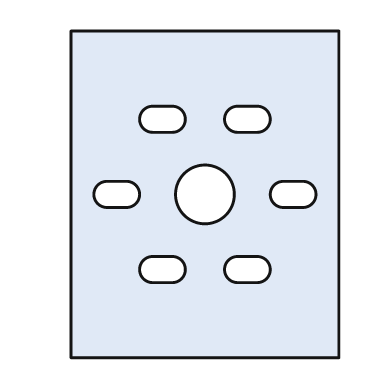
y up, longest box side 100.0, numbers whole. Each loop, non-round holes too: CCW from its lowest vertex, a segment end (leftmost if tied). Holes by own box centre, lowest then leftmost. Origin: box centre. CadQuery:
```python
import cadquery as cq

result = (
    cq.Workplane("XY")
    .moveTo(-41.0, -50.0)
    .lineTo(41.0, -50.0)
    .lineTo(41.0, 50.0)
    .lineTo(-41.0, 50.0)
    .close()
    .moveTo(-16.0, -27.0)
    .lineTo(-10.0, -27.0)
    .threePointArc((-6.0, -23.0), (-10.0, -19.0))
    .lineTo(-16.0, -19.0)
    .threePointArc((-20.0, -23.0), (-16.0, -27.0))
    .close()
    .moveTo(10.0, -27.0)
    .lineTo(16.0, -27.0)
    .threePointArc((20.0, -23.0), (16.0, -19.0))
    .lineTo(10.0, -19.0)
    .threePointArc((6.0, -23.0), (10.0, -27.0))
    .close()
    .moveTo(-30.0, -4.0)
    .lineTo(-24.0, -4.0)
    .threePointArc((-20.0, 0.0), (-24.0, 4.0))
    .lineTo(-30.0, 4.0)
    .threePointArc((-34.0, 0.0), (-30.0, -4.0))
    .close()
    .moveTo(0.0, 0.0)
    .circle(9.0)
    .moveTo(24.0, -4.0)
    .lineTo(30.0, -4.0)
    .threePointArc((34.0, 0.0), (30.0, 4.0))
    .lineTo(24.0, 4.0)
    .threePointArc((20.0, 0.0), (24.0, -4.0))
    .close()
    .moveTo(-16.0, 19.0)
    .lineTo(-10.0, 19.0)
    .threePointArc((-6.0, 23.0), (-10.0, 27.0))
    .lineTo(-16.0, 27.0)
    .threePointArc((-20.0, 23.0), (-16.0, 19.0))
    .close()
    .moveTo(10.0, 19.0)
    .lineTo(16.0, 19.0)
    .threePointArc((20.0, 23.0), (16.0, 27.0))
    .lineTo(10.0, 27.0)
    .threePointArc((6.0, 23.0), (10.0, 19.0))
    .close()
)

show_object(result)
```